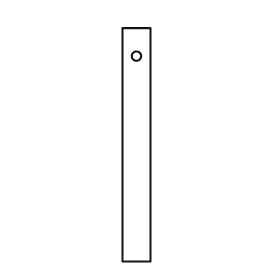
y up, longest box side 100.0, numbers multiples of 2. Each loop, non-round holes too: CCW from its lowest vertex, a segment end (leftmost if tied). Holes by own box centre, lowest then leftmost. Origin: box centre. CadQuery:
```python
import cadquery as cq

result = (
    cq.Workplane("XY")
    .moveTo(-6.0, -50.0)
    .lineTo(6.0, -50.0)
    .lineTo(6.0, 50.0)
    .lineTo(-6.0, 50.0)
    .close()
    .moveTo(0.0, 38.0)
    .circle(2.0)
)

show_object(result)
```